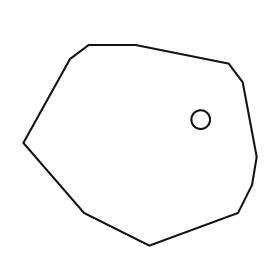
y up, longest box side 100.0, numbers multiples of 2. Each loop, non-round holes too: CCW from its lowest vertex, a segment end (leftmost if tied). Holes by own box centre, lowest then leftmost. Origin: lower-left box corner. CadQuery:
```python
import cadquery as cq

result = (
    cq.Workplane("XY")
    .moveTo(54.0, 0.0)
    .lineTo(92.0, 14.0)
    .lineTo(98.0, 26.0)
    .lineTo(100.0, 38.0)
    .lineTo(94.0, 70.0)
    .lineTo(88.0, 78.0)
    .lineTo(48.0, 86.0)
    .lineTo(28.0, 86.0)
    .lineTo(20.0, 80.0)
    .lineTo(0.0, 44.0)
    .lineTo(26.0, 14.0)
    .close()
    .moveTo(76.0, 54.0)
    .circle(4.0)
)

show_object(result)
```